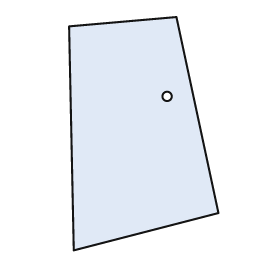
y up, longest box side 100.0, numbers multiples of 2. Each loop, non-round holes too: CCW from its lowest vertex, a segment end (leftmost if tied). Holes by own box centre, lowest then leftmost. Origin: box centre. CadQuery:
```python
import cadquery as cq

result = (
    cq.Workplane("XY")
    .moveTo(-30.0, -50.0)
    .lineTo(32.0, -34.0)
    .lineTo(14.0, 50.0)
    .lineTo(-32.0, 46.0)
    .close()
    .moveTo(10.0, 16.0)
    .circle(2.0)
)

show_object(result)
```